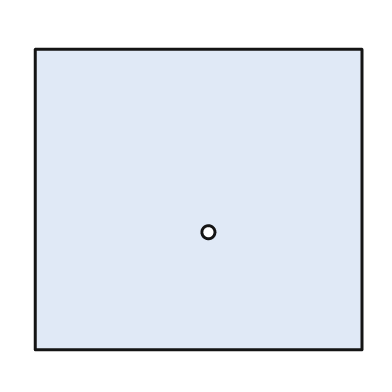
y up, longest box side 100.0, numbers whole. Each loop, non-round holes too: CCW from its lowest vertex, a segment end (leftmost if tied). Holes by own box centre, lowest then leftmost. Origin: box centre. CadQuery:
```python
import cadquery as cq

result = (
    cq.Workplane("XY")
    .moveTo(-50.0, -46.0)
    .lineTo(50.0, -46.0)
    .lineTo(50.0, 46.0)
    .lineTo(-50.0, 46.0)
    .close()
    .moveTo(3.0, -10.0)
    .circle(2.0)
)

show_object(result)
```